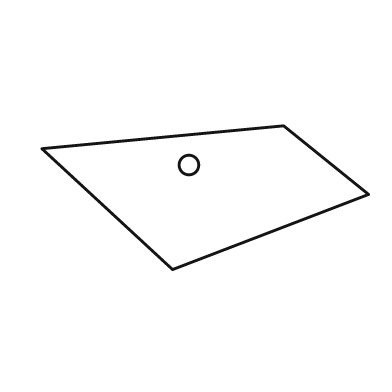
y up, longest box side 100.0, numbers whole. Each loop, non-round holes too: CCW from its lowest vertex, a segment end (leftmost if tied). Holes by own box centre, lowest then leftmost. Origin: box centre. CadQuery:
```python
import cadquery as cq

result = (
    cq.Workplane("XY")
    .moveTo(-10.0, -22.0)
    .lineTo(50.0, 1.0)
    .lineTo(24.0, 22.0)
    .lineTo(-50.0, 15.0)
    .close()
    .moveTo(-5.0, 10.0)
    .circle(3.0)
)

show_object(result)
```